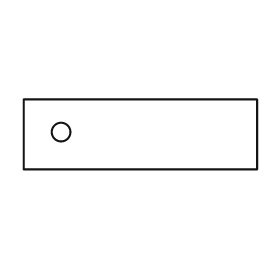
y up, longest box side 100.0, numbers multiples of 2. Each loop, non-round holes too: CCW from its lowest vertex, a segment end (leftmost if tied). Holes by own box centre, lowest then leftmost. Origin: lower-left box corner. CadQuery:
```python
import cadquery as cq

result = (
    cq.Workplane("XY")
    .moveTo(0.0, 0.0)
    .lineTo(100.0, 0.0)
    .lineTo(100.0, 30.0)
    .lineTo(0.0, 30.0)
    .close()
    .moveTo(16.0, 16.0)
    .circle(4.0)
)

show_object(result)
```